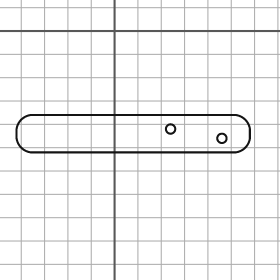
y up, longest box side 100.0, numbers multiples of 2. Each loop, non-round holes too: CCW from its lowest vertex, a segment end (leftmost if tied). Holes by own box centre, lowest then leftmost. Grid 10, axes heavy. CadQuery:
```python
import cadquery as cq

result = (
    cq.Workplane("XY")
    .moveTo(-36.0, -52.0)
    .lineTo(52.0, -52.0)
    .threePointArc((56.0, -50.0), (58.0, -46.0))
    .lineTo(58.0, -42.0)
    .threePointArc((56.0, -38.0), (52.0, -36.0))
    .lineTo(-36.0, -36.0)
    .threePointArc((-40.0, -38.0), (-42.0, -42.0))
    .lineTo(-42.0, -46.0)
    .threePointArc((-40.0, -50.0), (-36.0, -52.0))
    .close()
    .moveTo(46.0, -46.0)
    .circle(2.0)
    .moveTo(24.0, -42.0)
    .circle(2.0)
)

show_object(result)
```